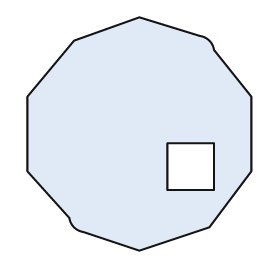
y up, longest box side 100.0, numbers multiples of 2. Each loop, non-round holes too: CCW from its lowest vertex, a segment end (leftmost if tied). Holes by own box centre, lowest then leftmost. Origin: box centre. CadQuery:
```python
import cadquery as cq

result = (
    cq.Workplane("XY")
    .moveTo(0.0, -50.0)
    .lineTo(30.0, -40.0)
    .lineTo(48.0, -16.0)
    .lineTo(48.0, 16.0)
    .lineTo(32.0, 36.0)
    .threePointArc((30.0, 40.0), (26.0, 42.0))
    .lineTo(0.0, 50.0)
    .lineTo(-28.0, 40.0)
    .lineTo(-48.0, 16.0)
    .lineTo(-48.0, -16.0)
    .lineTo(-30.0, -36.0)
    .threePointArc((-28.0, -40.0), (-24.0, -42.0))
    .close()
    .moveTo(12.0, -24.0)
    .lineTo(32.0, -24.0)
    .lineTo(32.0, -4.0)
    .lineTo(12.0, -4.0)
    .close()
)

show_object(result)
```